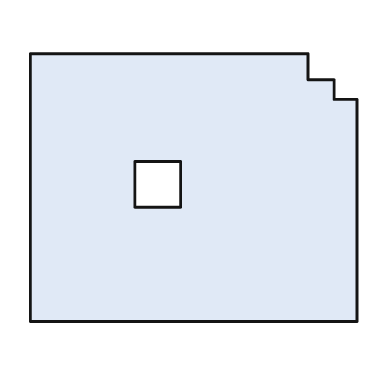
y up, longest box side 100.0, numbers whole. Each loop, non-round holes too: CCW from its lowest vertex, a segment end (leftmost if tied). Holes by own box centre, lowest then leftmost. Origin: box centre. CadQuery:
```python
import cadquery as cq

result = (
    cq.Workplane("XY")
    .moveTo(-50.0, -41.0)
    .lineTo(50.0, -41.0)
    .lineTo(50.0, 27.0)
    .lineTo(43.0, 27.0)
    .lineTo(43.0, 33.0)
    .lineTo(35.0, 33.0)
    .lineTo(35.0, 41.0)
    .lineTo(-50.0, 41.0)
    .close()
    .moveTo(-18.0, -6.0)
    .lineTo(-4.0, -6.0)
    .lineTo(-4.0, 8.0)
    .lineTo(-18.0, 8.0)
    .close()
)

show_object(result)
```